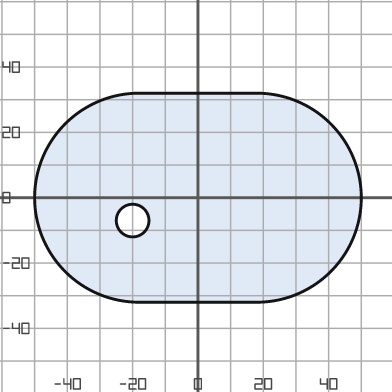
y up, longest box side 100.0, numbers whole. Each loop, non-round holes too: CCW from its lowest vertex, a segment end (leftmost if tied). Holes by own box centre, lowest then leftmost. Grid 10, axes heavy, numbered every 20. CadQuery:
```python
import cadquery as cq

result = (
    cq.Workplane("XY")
    .moveTo(-18.0, -32.0)
    .lineTo(18.0, -32.0)
    .threePointArc((50.0, 0.0), (18.0, 32.0))
    .lineTo(-18.0, 32.0)
    .threePointArc((-50.0, 0.0), (-18.0, -32.0))
    .close()
    .moveTo(-20.0, -7.0)
    .circle(5.0)
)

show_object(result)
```